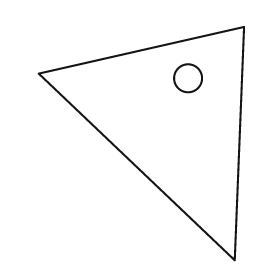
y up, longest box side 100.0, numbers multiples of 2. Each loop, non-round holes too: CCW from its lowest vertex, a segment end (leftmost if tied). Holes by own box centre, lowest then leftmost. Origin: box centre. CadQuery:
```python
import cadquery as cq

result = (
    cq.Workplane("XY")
    .moveTo(40.0, -50.0)
    .lineTo(44.0, 50.0)
    .lineTo(-44.0, 30.0)
    .close()
    .moveTo(20.0, 28.0)
    .circle(6.0)
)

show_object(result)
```